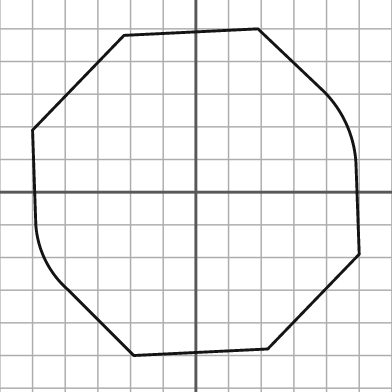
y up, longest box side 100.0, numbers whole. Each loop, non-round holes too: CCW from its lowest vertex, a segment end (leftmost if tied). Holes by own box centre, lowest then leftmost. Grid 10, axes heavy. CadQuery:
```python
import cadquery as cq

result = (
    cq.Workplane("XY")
    .moveTo(-19.0, -50.0)
    .lineTo(22.0, -48.0)
    .lineTo(50.0, -19.0)
    .lineTo(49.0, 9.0)
    .threePointArc((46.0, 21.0), (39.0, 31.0))
    .lineTo(19.0, 50.0)
    .lineTo(-22.0, 48.0)
    .lineTo(-50.0, 19.0)
    .lineTo(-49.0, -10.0)
    .threePointArc((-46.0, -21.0), (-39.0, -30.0))
    .close()
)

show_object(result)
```